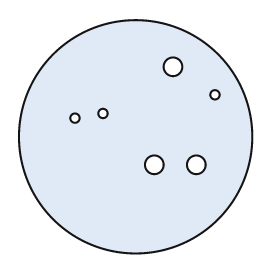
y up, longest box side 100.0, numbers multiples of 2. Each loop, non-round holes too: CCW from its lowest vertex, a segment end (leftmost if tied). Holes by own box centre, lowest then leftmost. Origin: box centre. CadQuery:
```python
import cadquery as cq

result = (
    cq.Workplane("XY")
    .moveTo(0.0, 0.0)
    .circle(50.0)
    .moveTo(8.0, -12.0)
    .circle(4.0)
    .moveTo(26.0, -12.0)
    .circle(4.0)
    .moveTo(-26.0, 8.0)
    .circle(2.0)
    .moveTo(-14.0, 10.0)
    .circle(2.0)
    .moveTo(34.0, 18.0)
    .circle(2.0)
    .moveTo(16.0, 30.0)
    .circle(4.0)
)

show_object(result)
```